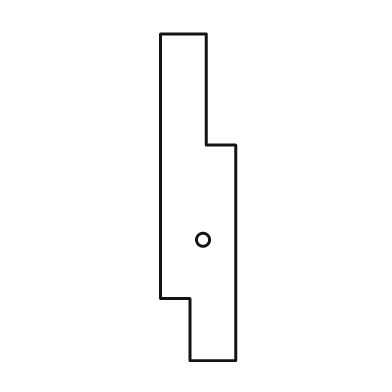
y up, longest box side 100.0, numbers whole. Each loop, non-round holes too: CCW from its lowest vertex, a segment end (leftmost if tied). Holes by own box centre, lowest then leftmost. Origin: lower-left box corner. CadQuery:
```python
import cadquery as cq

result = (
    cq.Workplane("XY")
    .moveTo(9.0, 0.0)
    .lineTo(23.0, 0.0)
    .lineTo(23.0, 66.0)
    .lineTo(14.0, 66.0)
    .lineTo(14.0, 100.0)
    .lineTo(0.0, 100.0)
    .lineTo(0.0, 19.0)
    .lineTo(9.0, 19.0)
    .close()
    .moveTo(13.0, 37.0)
    .circle(2.0)
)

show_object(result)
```